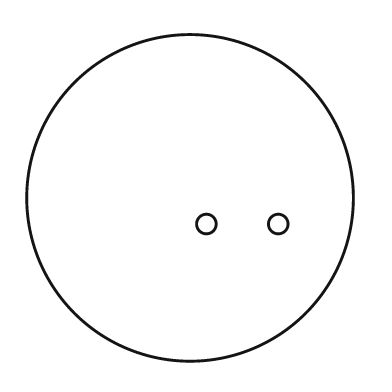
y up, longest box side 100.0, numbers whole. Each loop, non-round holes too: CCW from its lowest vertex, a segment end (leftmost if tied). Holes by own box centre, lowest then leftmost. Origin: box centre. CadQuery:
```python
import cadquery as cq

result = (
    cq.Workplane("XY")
    .moveTo(0.0, 0.0)
    .circle(50.0)
    .moveTo(5.0, -8.0)
    .circle(3.0)
    .moveTo(27.0, -8.0)
    .circle(3.0)
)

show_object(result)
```